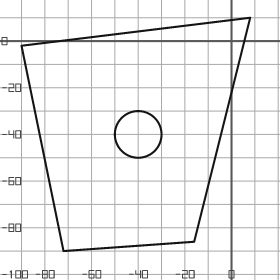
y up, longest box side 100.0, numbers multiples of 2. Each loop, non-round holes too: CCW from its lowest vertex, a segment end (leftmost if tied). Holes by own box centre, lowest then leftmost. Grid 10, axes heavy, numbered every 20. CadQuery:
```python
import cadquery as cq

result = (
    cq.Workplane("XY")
    .moveTo(-72.0, -90.0)
    .lineTo(-16.0, -86.0)
    .lineTo(8.0, 10.0)
    .lineTo(-90.0, -2.0)
    .close()
    .moveTo(-40.0, -40.0)
    .circle(10.0)
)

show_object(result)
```